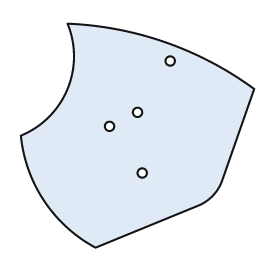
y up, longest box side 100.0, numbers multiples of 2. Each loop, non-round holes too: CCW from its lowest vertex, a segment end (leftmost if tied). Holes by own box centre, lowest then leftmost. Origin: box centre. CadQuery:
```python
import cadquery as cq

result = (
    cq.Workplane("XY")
    .moveTo(-18.0, -48.0)
    .lineTo(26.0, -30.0)
    .threePointArc((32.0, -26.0), (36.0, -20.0))
    .lineTo(50.0, 20.0)
    .threePointArc((12.0, 40.0), (-30.0, 48.0))
    .threePointArc((-30.0, 20.0), (-50.0, 0.0))
    .threePointArc((-40.0, -28.0), (-18.0, -48.0))
    .close()
    .moveTo(2.0, -16.0)
    .circle(2.0)
    .moveTo(-12.0, 4.0)
    .circle(2.0)
    .moveTo(0.0, 10.0)
    .circle(2.0)
    .moveTo(14.0, 32.0)
    .circle(2.0)
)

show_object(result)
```